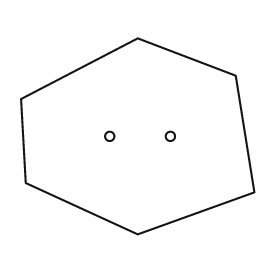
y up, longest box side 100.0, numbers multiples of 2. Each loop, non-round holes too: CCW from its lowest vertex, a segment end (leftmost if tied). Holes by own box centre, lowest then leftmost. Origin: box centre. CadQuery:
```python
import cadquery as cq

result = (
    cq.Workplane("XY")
    .moveTo(0.0, -42.0)
    .lineTo(50.0, -24.0)
    .lineTo(42.0, 26.0)
    .lineTo(0.0, 42.0)
    .lineTo(-50.0, 16.0)
    .lineTo(-48.0, -20.0)
    .close()
    .moveTo(-12.0, 0.0)
    .circle(2.0)
    .moveTo(14.0, 0.0)
    .circle(2.0)
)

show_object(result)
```